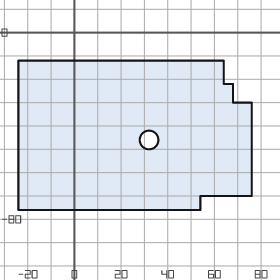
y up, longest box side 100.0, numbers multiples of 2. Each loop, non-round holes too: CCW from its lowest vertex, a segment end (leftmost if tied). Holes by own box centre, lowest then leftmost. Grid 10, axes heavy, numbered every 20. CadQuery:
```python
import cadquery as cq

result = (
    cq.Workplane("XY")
    .moveTo(-24.0, -76.0)
    .lineTo(54.0, -76.0)
    .lineTo(54.0, -70.0)
    .lineTo(76.0, -70.0)
    .lineTo(76.0, -30.0)
    .lineTo(68.0, -30.0)
    .lineTo(68.0, -22.0)
    .lineTo(64.0, -22.0)
    .lineTo(64.0, -12.0)
    .lineTo(-24.0, -12.0)
    .close()
    .moveTo(32.0, -46.0)
    .circle(4.0)
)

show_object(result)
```